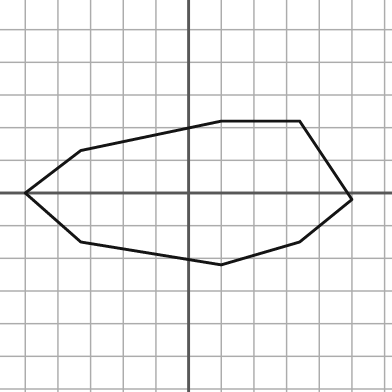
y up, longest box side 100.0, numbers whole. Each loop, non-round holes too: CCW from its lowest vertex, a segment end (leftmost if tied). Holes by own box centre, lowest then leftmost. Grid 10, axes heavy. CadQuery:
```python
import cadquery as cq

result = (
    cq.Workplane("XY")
    .moveTo(10.0, -22.0)
    .lineTo(34.0, -15.0)
    .lineTo(50.0, -2.0)
    .lineTo(34.0, 22.0)
    .lineTo(10.0, 22.0)
    .lineTo(-33.0, 13.0)
    .lineTo(-50.0, 0.0)
    .lineTo(-33.0, -15.0)
    .close()
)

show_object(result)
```